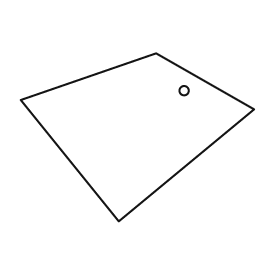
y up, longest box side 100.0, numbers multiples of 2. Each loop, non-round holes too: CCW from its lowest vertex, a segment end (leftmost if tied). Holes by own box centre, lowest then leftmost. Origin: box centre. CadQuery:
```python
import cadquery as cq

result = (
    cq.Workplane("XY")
    .moveTo(-8.0, -36.0)
    .lineTo(50.0, 12.0)
    .lineTo(8.0, 36.0)
    .lineTo(-50.0, 16.0)
    .close()
    .moveTo(20.0, 20.0)
    .circle(2.0)
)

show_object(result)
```